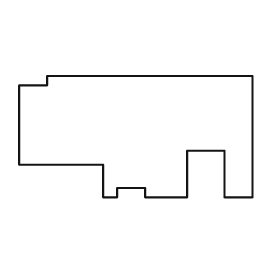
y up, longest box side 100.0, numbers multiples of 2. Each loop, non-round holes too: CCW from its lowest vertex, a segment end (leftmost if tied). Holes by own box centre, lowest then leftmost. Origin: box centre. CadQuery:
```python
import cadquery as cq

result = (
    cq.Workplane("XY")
    .moveTo(-14.0, -26.0)
    .lineTo(-8.0, -26.0)
    .lineTo(-8.0, -22.0)
    .lineTo(4.0, -22.0)
    .lineTo(4.0, -26.0)
    .lineTo(22.0, -26.0)
    .lineTo(22.0, -6.0)
    .lineTo(38.0, -6.0)
    .lineTo(38.0, -26.0)
    .lineTo(50.0, -26.0)
    .lineTo(50.0, 26.0)
    .lineTo(-38.0, 26.0)
    .lineTo(-38.0, 22.0)
    .lineTo(-50.0, 22.0)
    .lineTo(-50.0, -12.0)
    .lineTo(-14.0, -12.0)
    .close()
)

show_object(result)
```